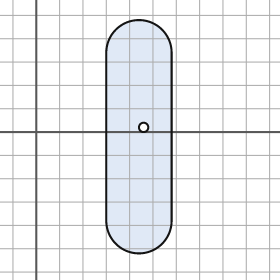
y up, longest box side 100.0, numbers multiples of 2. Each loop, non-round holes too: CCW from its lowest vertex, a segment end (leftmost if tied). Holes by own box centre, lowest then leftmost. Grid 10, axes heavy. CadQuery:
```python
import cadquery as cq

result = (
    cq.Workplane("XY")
    .moveTo(30.0, -38.0)
    .threePointArc((44.0, -52.0), (58.0, -38.0))
    .lineTo(58.0, 34.0)
    .threePointArc((44.0, 48.0), (30.0, 34.0))
    .close()
    .moveTo(46.0, 2.0)
    .circle(2.0)
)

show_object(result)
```